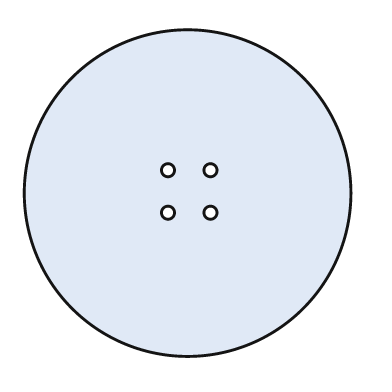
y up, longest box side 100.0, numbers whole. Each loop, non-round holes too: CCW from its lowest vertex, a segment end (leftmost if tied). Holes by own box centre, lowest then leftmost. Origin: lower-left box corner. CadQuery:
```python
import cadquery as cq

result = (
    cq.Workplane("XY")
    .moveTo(50.0, 50.0)
    .circle(50.0)
    .moveTo(44.0, 44.0)
    .circle(2.0)
    .moveTo(57.0, 44.0)
    .circle(2.0)
    .moveTo(44.0, 57.0)
    .circle(2.0)
    .moveTo(57.0, 57.0)
    .circle(2.0)
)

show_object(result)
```